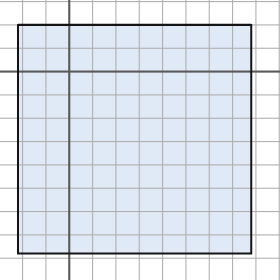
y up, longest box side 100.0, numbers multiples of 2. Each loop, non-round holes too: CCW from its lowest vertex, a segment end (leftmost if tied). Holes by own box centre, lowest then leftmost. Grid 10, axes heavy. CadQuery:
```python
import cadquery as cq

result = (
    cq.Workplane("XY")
    .moveTo(-22.0, -78.0)
    .lineTo(78.0, -78.0)
    .lineTo(78.0, 20.0)
    .lineTo(-22.0, 20.0)
    .close()
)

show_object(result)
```